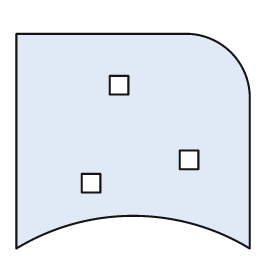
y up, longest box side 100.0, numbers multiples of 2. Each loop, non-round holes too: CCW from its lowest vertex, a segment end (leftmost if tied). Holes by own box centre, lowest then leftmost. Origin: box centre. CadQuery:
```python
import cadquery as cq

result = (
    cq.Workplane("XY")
    .moveTo(-50.0, -46.0)
    .threePointArc((0.0, -32.0), (50.0, -46.0))
    .lineTo(50.0, 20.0)
    .threePointArc((42.0, 38.0), (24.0, 46.0))
    .lineTo(-50.0, 46.0)
    .close()
    .moveTo(-22.0, -22.0)
    .lineTo(-14.0, -22.0)
    .lineTo(-14.0, -14.0)
    .lineTo(-22.0, -14.0)
    .close()
    .moveTo(20.0, -12.0)
    .lineTo(28.0, -12.0)
    .lineTo(28.0, -4.0)
    .lineTo(20.0, -4.0)
    .close()
    .moveTo(-10.0, 20.0)
    .lineTo(-2.0, 20.0)
    .lineTo(-2.0, 28.0)
    .lineTo(-10.0, 28.0)
    .close()
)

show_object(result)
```